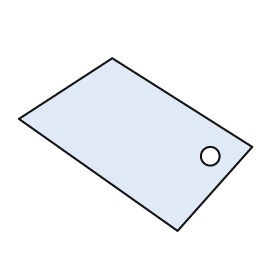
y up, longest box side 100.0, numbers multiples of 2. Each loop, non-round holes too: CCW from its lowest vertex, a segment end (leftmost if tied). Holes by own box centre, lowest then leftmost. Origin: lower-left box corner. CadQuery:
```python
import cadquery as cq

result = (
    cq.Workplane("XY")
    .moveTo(68.0, 0.0)
    .lineTo(100.0, 36.0)
    .lineTo(40.0, 74.0)
    .lineTo(0.0, 48.0)
    .close()
    .moveTo(82.0, 32.0)
    .circle(4.0)
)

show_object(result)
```